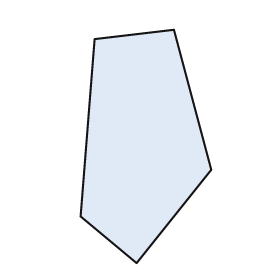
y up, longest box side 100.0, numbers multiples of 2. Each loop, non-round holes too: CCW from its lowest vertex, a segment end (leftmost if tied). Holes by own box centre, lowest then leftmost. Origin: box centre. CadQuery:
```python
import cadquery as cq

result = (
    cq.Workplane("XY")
    .moveTo(-4.0, -50.0)
    .lineTo(28.0, -10.0)
    .lineTo(12.0, 50.0)
    .lineTo(-22.0, 46.0)
    .lineTo(-28.0, -30.0)
    .close()
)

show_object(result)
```